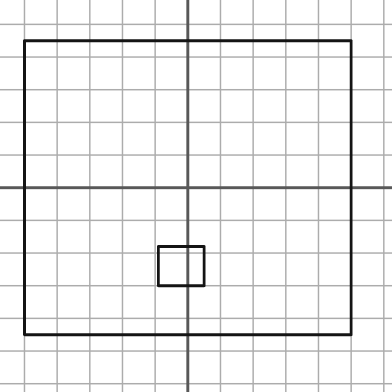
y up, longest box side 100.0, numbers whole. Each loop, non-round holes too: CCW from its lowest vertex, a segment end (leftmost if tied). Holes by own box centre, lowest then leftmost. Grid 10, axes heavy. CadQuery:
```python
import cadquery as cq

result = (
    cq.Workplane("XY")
    .moveTo(-50.0, -45.0)
    .lineTo(50.0, -45.0)
    .lineTo(50.0, 45.0)
    .lineTo(-50.0, 45.0)
    .close()
    .moveTo(-9.0, -30.0)
    .lineTo(5.0, -30.0)
    .lineTo(5.0, -18.0)
    .lineTo(-9.0, -18.0)
    .close()
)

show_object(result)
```